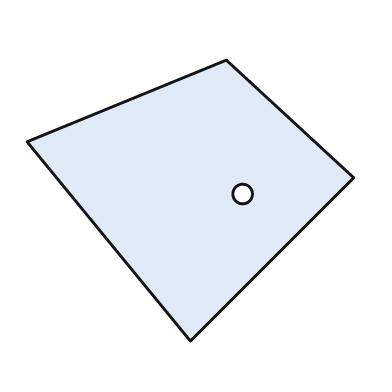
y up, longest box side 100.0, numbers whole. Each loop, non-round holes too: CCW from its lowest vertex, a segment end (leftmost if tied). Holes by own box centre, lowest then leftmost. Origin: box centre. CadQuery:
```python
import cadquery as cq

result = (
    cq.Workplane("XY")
    .moveTo(0.0, -43.0)
    .lineTo(50.0, 7.0)
    .lineTo(11.0, 43.0)
    .lineTo(-50.0, 18.0)
    .close()
    .moveTo(16.0, 2.0)
    .circle(3.0)
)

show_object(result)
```